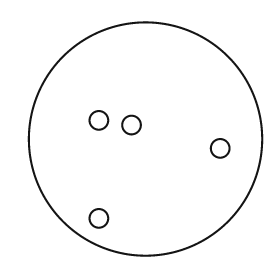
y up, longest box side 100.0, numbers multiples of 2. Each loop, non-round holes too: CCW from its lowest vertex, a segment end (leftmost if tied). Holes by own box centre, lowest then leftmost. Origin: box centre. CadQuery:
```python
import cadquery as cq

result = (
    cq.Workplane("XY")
    .moveTo(0.0, 0.0)
    .circle(50.0)
    .moveTo(-20.0, -34.0)
    .circle(4.0)
    .moveTo(32.0, -4.0)
    .circle(4.0)
    .moveTo(-6.0, 6.0)
    .circle(4.0)
    .moveTo(-20.0, 8.0)
    .circle(4.0)
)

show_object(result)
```